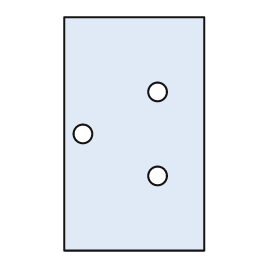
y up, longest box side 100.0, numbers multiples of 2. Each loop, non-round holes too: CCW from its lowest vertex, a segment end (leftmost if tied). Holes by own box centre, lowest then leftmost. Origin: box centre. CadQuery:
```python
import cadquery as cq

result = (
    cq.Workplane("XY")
    .moveTo(-30.0, -50.0)
    .lineTo(30.0, -50.0)
    .lineTo(30.0, 50.0)
    .lineTo(-30.0, 50.0)
    .close()
    .moveTo(10.0, -18.0)
    .circle(4.0)
    .moveTo(-22.0, 0.0)
    .circle(4.0)
    .moveTo(10.0, 18.0)
    .circle(4.0)
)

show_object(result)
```